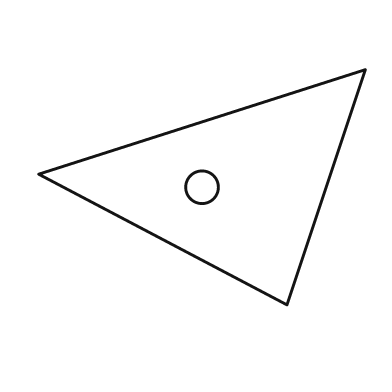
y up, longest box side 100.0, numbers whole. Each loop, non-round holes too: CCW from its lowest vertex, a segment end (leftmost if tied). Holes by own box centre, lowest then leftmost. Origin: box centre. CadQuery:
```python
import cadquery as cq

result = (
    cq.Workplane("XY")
    .moveTo(26.0, -36.0)
    .lineTo(50.0, 36.0)
    .lineTo(-50.0, 4.0)
    .close()
    .moveTo(0.0, 0.0)
    .circle(5.0)
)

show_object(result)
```